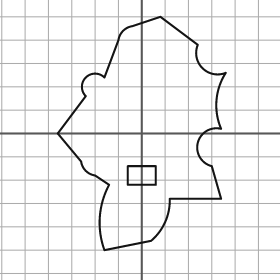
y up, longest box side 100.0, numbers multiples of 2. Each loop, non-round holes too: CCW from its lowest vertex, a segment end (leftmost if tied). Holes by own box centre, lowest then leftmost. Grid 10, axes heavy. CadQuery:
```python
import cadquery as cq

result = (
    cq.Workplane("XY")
    .moveTo(-16.0, -50.0)
    .lineTo(4.0, -46.0)
    .threePointArc((10.0, -38.0), (12.0, -28.0))
    .lineTo(34.0, -28.0)
    .lineTo(30.0, -14.0)
    .threePointArc((24.0, -4.0), (34.0, 2.0))
    .threePointArc((32.0, 14.0), (36.0, 26.0))
    .threePointArc((26.0, 28.0), (24.0, 38.0))
    .lineTo(8.0, 50.0)
    .lineTo(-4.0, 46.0)
    .threePointArc((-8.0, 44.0), (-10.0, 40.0))
    .lineTo(-16.0, 24.0)
    .threePointArc((-24.0, 24.0), (-24.0, 16.0))
    .lineTo(-36.0, 0.0)
    .lineTo(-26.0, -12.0)
    .threePointArc((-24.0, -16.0), (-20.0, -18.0))
    .lineTo(-14.0, -22.0)
    .threePointArc((-18.0, -36.0), (-16.0, -50.0))
    .close()
    .moveTo(-6.0, -22.0)
    .lineTo(6.0, -22.0)
    .lineTo(6.0, -14.0)
    .lineTo(-6.0, -14.0)
    .close()
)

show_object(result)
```